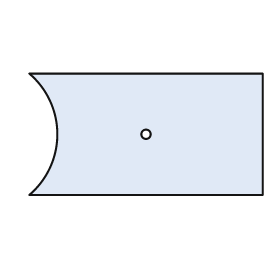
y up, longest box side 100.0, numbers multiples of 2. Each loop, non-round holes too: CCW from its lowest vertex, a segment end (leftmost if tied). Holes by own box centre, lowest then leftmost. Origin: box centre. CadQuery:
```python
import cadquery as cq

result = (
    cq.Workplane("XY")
    .moveTo(-50.0, -26.0)
    .lineTo(50.0, -26.0)
    .lineTo(50.0, 26.0)
    .lineTo(-50.0, 26.0)
    .threePointArc((-38.0, 0.0), (-50.0, -26.0))
    .close()
    .moveTo(0.0, 0.0)
    .circle(2.0)
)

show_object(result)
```